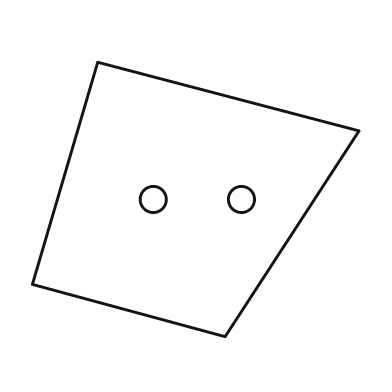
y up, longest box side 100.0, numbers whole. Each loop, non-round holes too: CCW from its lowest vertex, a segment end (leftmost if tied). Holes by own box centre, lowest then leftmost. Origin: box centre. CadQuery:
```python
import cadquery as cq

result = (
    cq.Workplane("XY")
    .moveTo(9.0, -42.0)
    .lineTo(50.0, 21.0)
    .lineTo(-30.0, 42.0)
    .lineTo(-50.0, -26.0)
    .close()
    .moveTo(-13.0, 0.0)
    .circle(4.0)
    .moveTo(14.0, 0.0)
    .circle(4.0)
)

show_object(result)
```